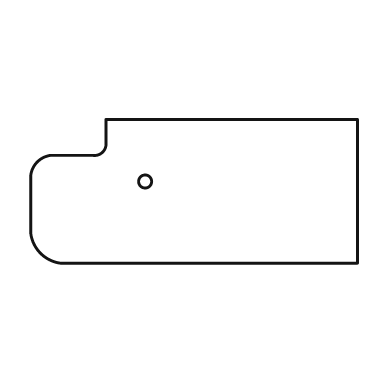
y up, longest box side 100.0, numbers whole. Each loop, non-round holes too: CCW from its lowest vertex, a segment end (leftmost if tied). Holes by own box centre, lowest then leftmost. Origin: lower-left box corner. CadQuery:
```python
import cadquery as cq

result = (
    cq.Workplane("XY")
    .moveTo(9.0, 0.0)
    .lineTo(100.0, 0.0)
    .lineTo(100.0, 44.0)
    .lineTo(23.0, 44.0)
    .lineTo(23.0, 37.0)
    .threePointArc((22.0, 34.0), (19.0, 33.0))
    .lineTo(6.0, 33.0)
    .threePointArc((2.0, 31.0), (0.0, 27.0))
    .lineTo(0.0, 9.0)
    .threePointArc((3.0, 3.0), (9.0, 0.0))
    .close()
    .moveTo(35.0, 25.0)
    .circle(2.0)
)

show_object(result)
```